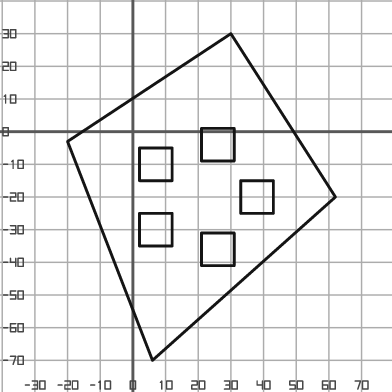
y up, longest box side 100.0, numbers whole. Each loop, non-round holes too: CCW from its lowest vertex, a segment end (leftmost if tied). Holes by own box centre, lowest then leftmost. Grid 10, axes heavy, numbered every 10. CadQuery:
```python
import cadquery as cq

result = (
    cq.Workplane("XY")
    .moveTo(6.0, -70.0)
    .lineTo(62.0, -20.0)
    .lineTo(30.0, 30.0)
    .lineTo(-20.0, -3.0)
    .close()
    .moveTo(21.0, -41.0)
    .lineTo(31.0, -41.0)
    .lineTo(31.0, -31.0)
    .lineTo(21.0, -31.0)
    .close()
    .moveTo(2.0, -35.0)
    .lineTo(12.0, -35.0)
    .lineTo(12.0, -25.0)
    .lineTo(2.0, -25.0)
    .close()
    .moveTo(33.0, -25.0)
    .lineTo(43.0, -25.0)
    .lineTo(43.0, -15.0)
    .lineTo(33.0, -15.0)
    .close()
    .moveTo(2.0, -15.0)
    .lineTo(12.0, -15.0)
    .lineTo(12.0, -5.0)
    .lineTo(2.0, -5.0)
    .close()
    .moveTo(21.0, -9.0)
    .lineTo(31.0, -9.0)
    .lineTo(31.0, 1.0)
    .lineTo(21.0, 1.0)
    .close()
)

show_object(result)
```